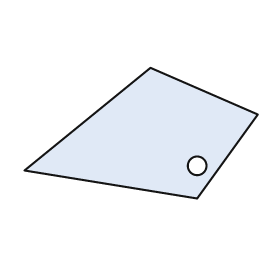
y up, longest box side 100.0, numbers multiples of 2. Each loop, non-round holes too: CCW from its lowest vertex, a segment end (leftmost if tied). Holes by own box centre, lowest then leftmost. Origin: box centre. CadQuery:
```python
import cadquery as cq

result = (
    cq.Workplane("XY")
    .moveTo(24.0, -28.0)
    .lineTo(50.0, 8.0)
    .lineTo(4.0, 28.0)
    .lineTo(-50.0, -16.0)
    .close()
    .moveTo(24.0, -14.0)
    .circle(4.0)
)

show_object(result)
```